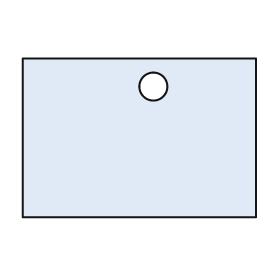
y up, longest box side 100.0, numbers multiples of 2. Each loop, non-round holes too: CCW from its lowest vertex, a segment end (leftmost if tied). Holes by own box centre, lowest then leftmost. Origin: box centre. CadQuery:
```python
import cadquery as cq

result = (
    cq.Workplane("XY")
    .moveTo(-50.0, -34.0)
    .lineTo(50.0, -34.0)
    .lineTo(50.0, 34.0)
    .lineTo(-50.0, 34.0)
    .close()
    .moveTo(6.0, 22.0)
    .circle(6.0)
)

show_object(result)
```